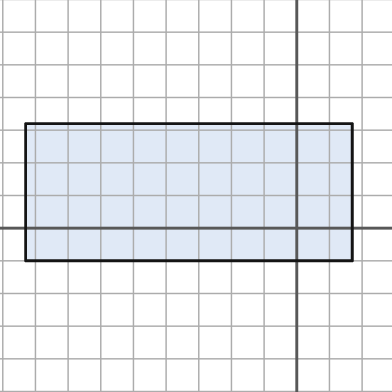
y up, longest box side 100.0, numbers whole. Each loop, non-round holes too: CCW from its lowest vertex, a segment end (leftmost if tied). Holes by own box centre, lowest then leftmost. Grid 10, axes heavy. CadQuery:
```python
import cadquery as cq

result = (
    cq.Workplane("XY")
    .moveTo(-83.0, -10.0)
    .lineTo(17.0, -10.0)
    .lineTo(17.0, 32.0)
    .lineTo(-83.0, 32.0)
    .close()
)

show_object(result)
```